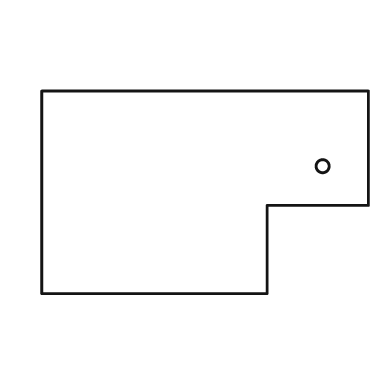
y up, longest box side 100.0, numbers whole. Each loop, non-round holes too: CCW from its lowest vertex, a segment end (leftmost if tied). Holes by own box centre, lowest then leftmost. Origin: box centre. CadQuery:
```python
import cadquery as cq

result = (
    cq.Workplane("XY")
    .moveTo(-50.0, -31.0)
    .lineTo(19.0, -31.0)
    .lineTo(19.0, -4.0)
    .lineTo(50.0, -4.0)
    .lineTo(50.0, 31.0)
    .lineTo(-50.0, 31.0)
    .close()
    .moveTo(36.0, 8.0)
    .circle(2.0)
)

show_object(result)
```